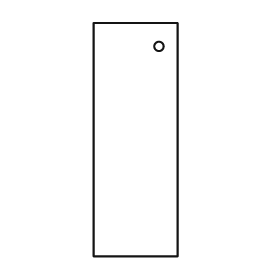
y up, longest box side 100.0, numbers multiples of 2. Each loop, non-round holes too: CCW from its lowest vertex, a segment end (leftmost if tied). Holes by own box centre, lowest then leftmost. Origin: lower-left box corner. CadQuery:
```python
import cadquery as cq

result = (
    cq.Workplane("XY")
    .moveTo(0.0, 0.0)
    .lineTo(36.0, 0.0)
    .lineTo(36.0, 100.0)
    .lineTo(0.0, 100.0)
    .close()
    .moveTo(28.0, 90.0)
    .circle(2.0)
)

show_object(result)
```